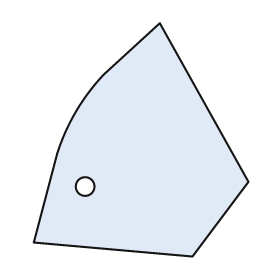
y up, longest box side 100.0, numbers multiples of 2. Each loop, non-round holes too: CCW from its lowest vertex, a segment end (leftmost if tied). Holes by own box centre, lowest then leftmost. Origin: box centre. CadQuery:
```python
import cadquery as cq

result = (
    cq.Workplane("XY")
    .moveTo(22.0, -50.0)
    .lineTo(46.0, -18.0)
    .lineTo(8.0, 50.0)
    .lineTo(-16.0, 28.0)
    .threePointArc((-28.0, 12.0), (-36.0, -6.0))
    .lineTo(-46.0, -44.0)
    .close()
    .moveTo(-24.0, -20.0)
    .circle(4.0)
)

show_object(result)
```